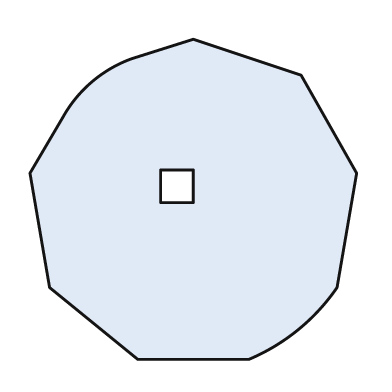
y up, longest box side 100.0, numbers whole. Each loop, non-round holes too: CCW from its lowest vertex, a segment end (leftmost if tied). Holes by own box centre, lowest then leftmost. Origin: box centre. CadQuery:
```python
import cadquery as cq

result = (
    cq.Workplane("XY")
    .moveTo(-17.0, -49.0)
    .lineTo(17.0, -49.0)
    .threePointArc((32.0, -40.0), (44.0, -27.0))
    .lineTo(50.0, 8.0)
    .lineTo(33.0, 38.0)
    .lineTo(0.0, 49.0)
    .lineTo(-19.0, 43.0)
    .threePointArc((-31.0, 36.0), (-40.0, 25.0))
    .lineTo(-50.0, 8.0)
    .lineTo(-44.0, -27.0)
    .close()
    .moveTo(-10.0, -1.0)
    .lineTo(0.0, -1.0)
    .lineTo(0.0, 9.0)
    .lineTo(-10.0, 9.0)
    .close()
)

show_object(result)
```